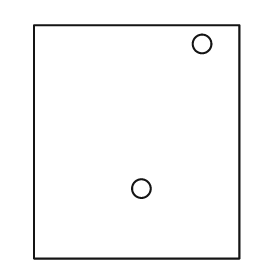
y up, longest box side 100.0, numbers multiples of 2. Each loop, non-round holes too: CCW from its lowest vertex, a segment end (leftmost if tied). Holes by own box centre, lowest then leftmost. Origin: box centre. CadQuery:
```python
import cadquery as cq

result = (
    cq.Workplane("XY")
    .moveTo(-44.0, -50.0)
    .lineTo(44.0, -50.0)
    .lineTo(44.0, 50.0)
    .lineTo(-44.0, 50.0)
    .close()
    .moveTo(2.0, -20.0)
    .circle(4.0)
    .moveTo(28.0, 42.0)
    .circle(4.0)
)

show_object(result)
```